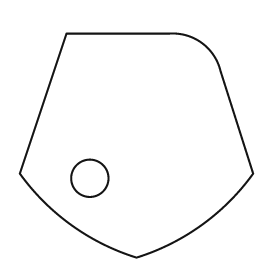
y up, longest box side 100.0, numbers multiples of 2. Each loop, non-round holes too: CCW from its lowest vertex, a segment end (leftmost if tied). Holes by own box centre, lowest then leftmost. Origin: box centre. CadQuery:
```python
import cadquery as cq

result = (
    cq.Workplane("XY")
    .moveTo(0.0, -48.0)
    .threePointArc((28.0, -34.0), (50.0, -12.0))
    .lineTo(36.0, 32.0)
    .threePointArc((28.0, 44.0), (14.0, 48.0))
    .lineTo(-30.0, 48.0)
    .lineTo(-50.0, -12.0)
    .threePointArc((-28.0, -34.0), (0.0, -48.0))
    .close()
    .moveTo(-20.0, -14.0)
    .circle(8.0)
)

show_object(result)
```